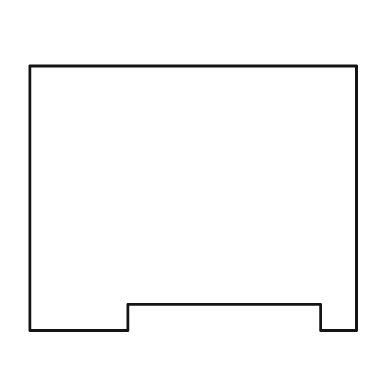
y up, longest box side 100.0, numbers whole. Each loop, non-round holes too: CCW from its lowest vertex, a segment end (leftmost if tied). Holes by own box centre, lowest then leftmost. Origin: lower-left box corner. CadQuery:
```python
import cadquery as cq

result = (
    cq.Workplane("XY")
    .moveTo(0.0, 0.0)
    .lineTo(30.0, 0.0)
    .lineTo(30.0, 8.0)
    .lineTo(89.0, 8.0)
    .lineTo(89.0, 0.0)
    .lineTo(100.0, 0.0)
    .lineTo(100.0, 81.0)
    .lineTo(0.0, 81.0)
    .close()
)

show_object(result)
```